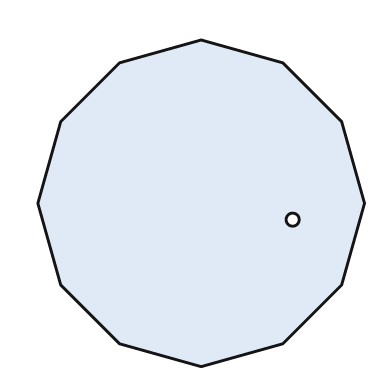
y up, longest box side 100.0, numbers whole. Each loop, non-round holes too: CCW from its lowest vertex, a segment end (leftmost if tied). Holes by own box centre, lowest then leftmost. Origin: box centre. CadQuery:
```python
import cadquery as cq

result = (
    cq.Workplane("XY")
    .moveTo(0.0, -50.0)
    .lineTo(25.0, -43.0)
    .lineTo(43.0, -25.0)
    .lineTo(50.0, 0.0)
    .lineTo(43.0, 25.0)
    .lineTo(25.0, 43.0)
    .lineTo(0.0, 50.0)
    .lineTo(-25.0, 43.0)
    .lineTo(-43.0, 25.0)
    .lineTo(-50.0, 0.0)
    .lineTo(-43.0, -25.0)
    .lineTo(-25.0, -43.0)
    .close()
    .moveTo(28.0, -5.0)
    .circle(2.0)
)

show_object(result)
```